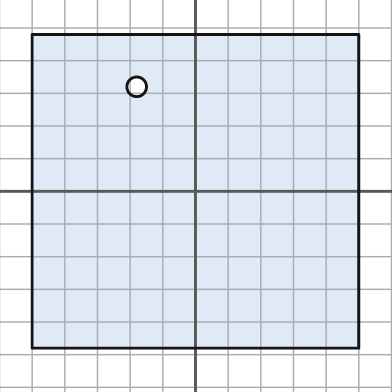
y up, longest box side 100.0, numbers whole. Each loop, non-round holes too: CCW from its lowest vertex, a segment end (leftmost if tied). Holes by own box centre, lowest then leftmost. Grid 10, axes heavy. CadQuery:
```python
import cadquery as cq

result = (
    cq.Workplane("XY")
    .moveTo(-50.0, -48.0)
    .lineTo(50.0, -48.0)
    .lineTo(50.0, 48.0)
    .lineTo(-50.0, 48.0)
    .close()
    .moveTo(-18.0, 32.0)
    .circle(3.0)
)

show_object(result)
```